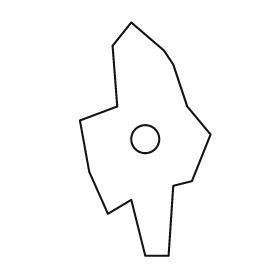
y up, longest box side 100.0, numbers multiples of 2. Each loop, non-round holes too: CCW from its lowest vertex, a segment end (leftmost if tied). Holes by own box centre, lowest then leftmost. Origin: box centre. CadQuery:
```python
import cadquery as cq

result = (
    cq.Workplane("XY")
    .moveTo(0.0, -50.0)
    .lineTo(10.0, -50.0)
    .lineTo(12.0, -20.0)
    .lineTo(20.0, -18.0)
    .lineTo(28.0, 2.0)
    .lineTo(18.0, 14.0)
    .lineTo(12.0, 32.0)
    .lineTo(8.0, 38.0)
    .lineTo(-6.0, 50.0)
    .lineTo(-14.0, 40.0)
    .lineTo(-12.0, 14.0)
    .lineTo(-28.0, 8.0)
    .lineTo(-24.0, -14.0)
    .lineTo(-16.0, -32.0)
    .lineTo(-6.0, -26.0)
    .close()
    .moveTo(0.0, 0.0)
    .circle(6.0)
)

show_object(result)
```